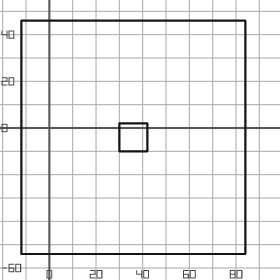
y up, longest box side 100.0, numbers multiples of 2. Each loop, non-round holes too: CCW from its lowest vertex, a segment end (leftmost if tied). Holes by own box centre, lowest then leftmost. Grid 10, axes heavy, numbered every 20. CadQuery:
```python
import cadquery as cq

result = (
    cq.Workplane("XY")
    .moveTo(-12.0, -54.0)
    .lineTo(84.0, -54.0)
    .lineTo(84.0, 46.0)
    .lineTo(-12.0, 46.0)
    .close()
    .moveTo(30.0, -10.0)
    .lineTo(42.0, -10.0)
    .lineTo(42.0, 2.0)
    .lineTo(30.0, 2.0)
    .close()
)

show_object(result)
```